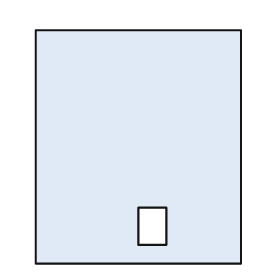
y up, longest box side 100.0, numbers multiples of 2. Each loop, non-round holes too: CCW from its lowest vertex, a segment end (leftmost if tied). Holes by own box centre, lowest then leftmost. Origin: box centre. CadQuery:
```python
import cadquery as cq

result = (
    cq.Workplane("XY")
    .moveTo(-44.0, -50.0)
    .lineTo(44.0, -50.0)
    .lineTo(44.0, 50.0)
    .lineTo(-44.0, 50.0)
    .close()
    .moveTo(0.0, -42.0)
    .lineTo(12.0, -42.0)
    .lineTo(12.0, -26.0)
    .lineTo(0.0, -26.0)
    .close()
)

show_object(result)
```